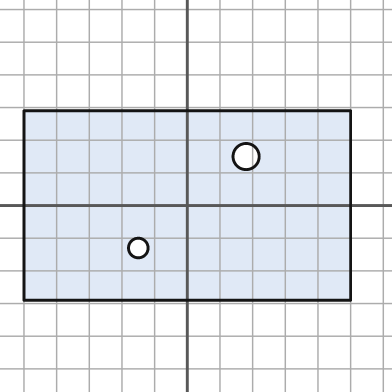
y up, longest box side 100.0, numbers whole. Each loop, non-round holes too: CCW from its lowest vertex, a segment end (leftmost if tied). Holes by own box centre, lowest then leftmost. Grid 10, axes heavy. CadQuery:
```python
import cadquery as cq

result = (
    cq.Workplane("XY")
    .moveTo(-50.0, -29.0)
    .lineTo(50.0, -29.0)
    .lineTo(50.0, 29.0)
    .lineTo(-50.0, 29.0)
    .close()
    .moveTo(-15.0, -13.0)
    .circle(3.0)
    .moveTo(18.0, 15.0)
    .circle(4.0)
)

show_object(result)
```